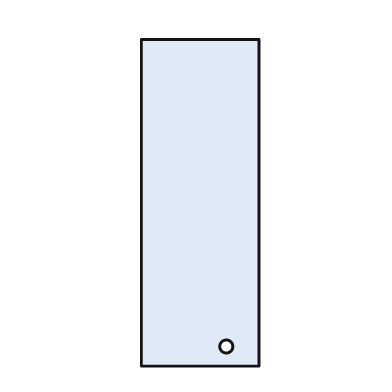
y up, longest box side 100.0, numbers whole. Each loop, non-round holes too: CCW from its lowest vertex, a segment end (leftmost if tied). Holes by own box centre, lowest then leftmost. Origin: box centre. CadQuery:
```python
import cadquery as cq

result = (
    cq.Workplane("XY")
    .moveTo(-18.0, -50.0)
    .lineTo(18.0, -50.0)
    .lineTo(18.0, 50.0)
    .lineTo(-18.0, 50.0)
    .close()
    .moveTo(8.0, -44.0)
    .circle(2.0)
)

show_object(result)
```